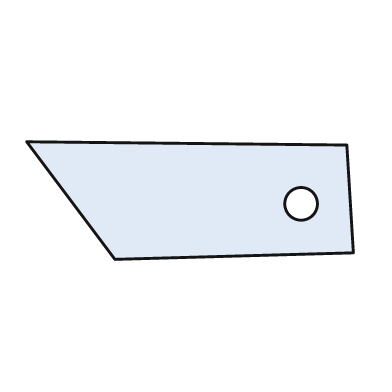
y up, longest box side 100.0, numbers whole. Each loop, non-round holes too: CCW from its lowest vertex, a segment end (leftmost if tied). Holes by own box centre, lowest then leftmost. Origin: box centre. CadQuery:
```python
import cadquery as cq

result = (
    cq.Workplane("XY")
    .moveTo(-23.0, -18.0)
    .lineTo(50.0, -16.0)
    .lineTo(48.0, 17.0)
    .lineTo(-50.0, 18.0)
    .close()
    .moveTo(34.0, -1.0)
    .circle(5.0)
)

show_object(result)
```